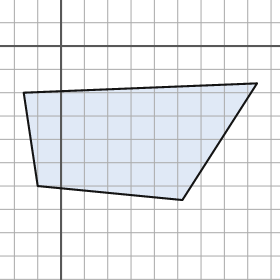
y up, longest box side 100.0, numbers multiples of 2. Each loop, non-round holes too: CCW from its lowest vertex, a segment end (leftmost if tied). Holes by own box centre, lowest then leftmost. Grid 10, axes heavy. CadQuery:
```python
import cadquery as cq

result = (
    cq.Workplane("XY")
    .moveTo(52.0, -66.0)
    .lineTo(84.0, -16.0)
    .lineTo(-16.0, -20.0)
    .lineTo(-10.0, -60.0)
    .close()
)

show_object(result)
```